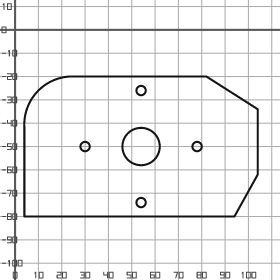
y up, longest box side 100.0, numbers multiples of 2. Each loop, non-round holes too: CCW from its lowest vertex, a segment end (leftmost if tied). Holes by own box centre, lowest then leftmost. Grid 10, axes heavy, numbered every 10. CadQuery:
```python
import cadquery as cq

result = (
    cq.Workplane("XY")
    .moveTo(4.0, -80.0)
    .lineTo(94.0, -80.0)
    .lineTo(104.0, -62.0)
    .lineTo(104.0, -34.0)
    .lineTo(82.0, -20.0)
    .lineTo(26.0, -20.0)
    .threePointArc((10.0, -26.0), (4.0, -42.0))
    .close()
    .moveTo(54.0, -74.0)
    .circle(2.0)
    .moveTo(30.0, -50.0)
    .circle(2.0)
    .moveTo(54.0, -50.0)
    .circle(8.0)
    .moveTo(78.0, -50.0)
    .circle(2.0)
    .moveTo(54.0, -26.0)
    .circle(2.0)
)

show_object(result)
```